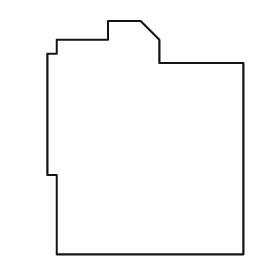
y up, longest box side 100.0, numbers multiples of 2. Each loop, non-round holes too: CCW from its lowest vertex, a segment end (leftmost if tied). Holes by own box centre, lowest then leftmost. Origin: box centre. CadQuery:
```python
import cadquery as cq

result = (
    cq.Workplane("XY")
    .moveTo(-38.0, -50.0)
    .lineTo(42.0, -50.0)
    .lineTo(42.0, 32.0)
    .lineTo(6.0, 32.0)
    .lineTo(6.0, 42.0)
    .lineTo(-2.0, 50.0)
    .lineTo(-16.0, 50.0)
    .lineTo(-16.0, 42.0)
    .lineTo(-38.0, 42.0)
    .lineTo(-38.0, 36.0)
    .lineTo(-42.0, 36.0)
    .lineTo(-42.0, -16.0)
    .lineTo(-38.0, -16.0)
    .close()
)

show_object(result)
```